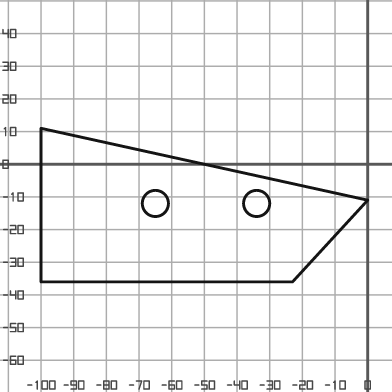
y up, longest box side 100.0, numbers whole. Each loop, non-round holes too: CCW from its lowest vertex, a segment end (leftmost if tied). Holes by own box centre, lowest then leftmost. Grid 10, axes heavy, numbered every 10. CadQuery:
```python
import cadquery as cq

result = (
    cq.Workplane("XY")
    .moveTo(-100.0, -36.0)
    .lineTo(-23.0, -36.0)
    .lineTo(0.0, -11.0)
    .lineTo(-100.0, 11.0)
    .close()
    .moveTo(-65.0, -12.0)
    .circle(4.0)
    .moveTo(-34.0, -12.0)
    .circle(4.0)
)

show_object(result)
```